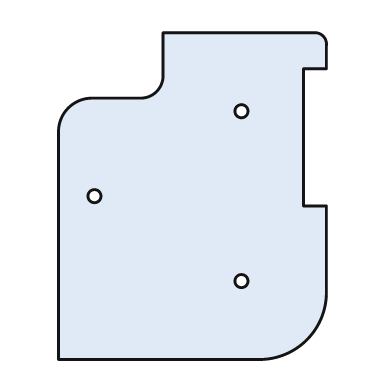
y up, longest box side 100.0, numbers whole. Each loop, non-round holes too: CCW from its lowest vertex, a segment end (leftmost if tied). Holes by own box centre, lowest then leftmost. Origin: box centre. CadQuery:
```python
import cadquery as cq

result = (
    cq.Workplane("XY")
    .moveTo(-41.0, -50.0)
    .lineTo(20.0, -50.0)
    .threePointArc((35.0, -44.0), (41.0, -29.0))
    .lineTo(41.0, -3.0)
    .lineTo(34.0, -3.0)
    .lineTo(34.0, 39.0)
    .lineTo(41.0, 39.0)
    .lineTo(41.0, 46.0)
    .threePointArc((40.0, 49.0), (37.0, 50.0))
    .lineTo(-9.0, 50.0)
    .lineTo(-9.0, 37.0)
    .threePointArc((-11.0, 32.0), (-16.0, 30.0))
    .lineTo(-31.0, 30.0)
    .threePointArc((-38.0, 27.0), (-41.0, 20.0))
    .close()
    .moveTo(15.0, -26.0)
    .circle(2.0)
    .moveTo(-30.0, 0.0)
    .circle(2.0)
    .moveTo(15.0, 26.0)
    .circle(2.0)
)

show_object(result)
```